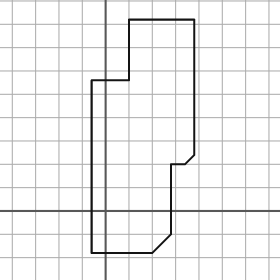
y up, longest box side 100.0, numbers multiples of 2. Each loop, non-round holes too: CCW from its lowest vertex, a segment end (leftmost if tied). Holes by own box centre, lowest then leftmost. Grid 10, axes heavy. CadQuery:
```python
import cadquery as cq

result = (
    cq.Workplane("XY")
    .moveTo(-6.0, -18.0)
    .lineTo(20.0, -18.0)
    .lineTo(28.0, -10.0)
    .lineTo(28.0, 20.0)
    .lineTo(34.0, 20.0)
    .lineTo(38.0, 24.0)
    .lineTo(38.0, 82.0)
    .lineTo(10.0, 82.0)
    .lineTo(10.0, 56.0)
    .lineTo(-6.0, 56.0)
    .close()
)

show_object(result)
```